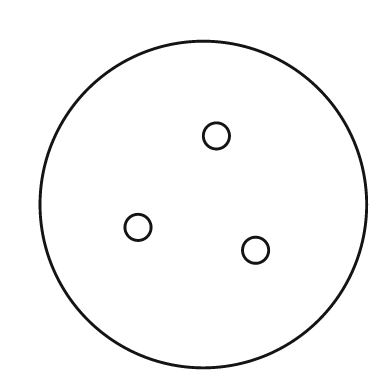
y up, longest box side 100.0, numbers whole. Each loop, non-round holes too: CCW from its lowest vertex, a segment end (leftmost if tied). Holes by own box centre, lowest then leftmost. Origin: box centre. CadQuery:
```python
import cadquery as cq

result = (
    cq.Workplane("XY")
    .moveTo(0.0, 0.0)
    .circle(50.0)
    .moveTo(16.0, -14.0)
    .circle(4.0)
    .moveTo(-20.0, -7.0)
    .circle(4.0)
    .moveTo(4.0, 21.0)
    .circle(4.0)
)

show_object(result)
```